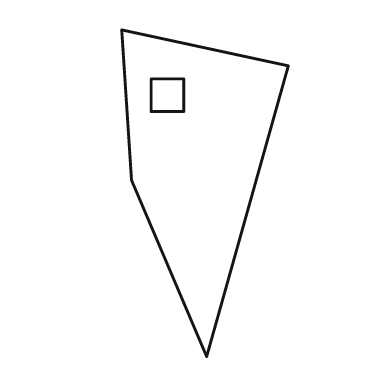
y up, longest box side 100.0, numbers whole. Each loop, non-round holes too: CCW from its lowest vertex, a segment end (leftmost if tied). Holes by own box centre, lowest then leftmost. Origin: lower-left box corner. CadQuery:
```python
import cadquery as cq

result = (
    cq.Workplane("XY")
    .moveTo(26.0, 0.0)
    .lineTo(51.0, 89.0)
    .lineTo(0.0, 100.0)
    .lineTo(3.0, 54.0)
    .close()
    .moveTo(9.0, 75.0)
    .lineTo(19.0, 75.0)
    .lineTo(19.0, 85.0)
    .lineTo(9.0, 85.0)
    .close()
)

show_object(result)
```